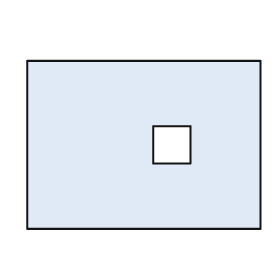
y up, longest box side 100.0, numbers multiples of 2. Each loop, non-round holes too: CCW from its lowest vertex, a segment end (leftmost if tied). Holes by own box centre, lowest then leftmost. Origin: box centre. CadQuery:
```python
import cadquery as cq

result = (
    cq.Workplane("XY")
    .moveTo(-50.0, -36.0)
    .lineTo(50.0, -36.0)
    .lineTo(50.0, 36.0)
    .lineTo(-50.0, 36.0)
    .close()
    .moveTo(4.0, -8.0)
    .lineTo(20.0, -8.0)
    .lineTo(20.0, 8.0)
    .lineTo(4.0, 8.0)
    .close()
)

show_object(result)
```